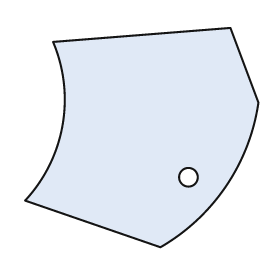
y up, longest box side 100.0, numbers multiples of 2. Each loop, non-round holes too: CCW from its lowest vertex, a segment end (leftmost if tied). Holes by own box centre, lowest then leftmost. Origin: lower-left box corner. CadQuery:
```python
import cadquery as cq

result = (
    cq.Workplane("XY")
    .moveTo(58.0, 0.0)
    .threePointArc((86.0, 26.0), (100.0, 62.0))
    .lineTo(88.0, 94.0)
    .lineTo(12.0, 88.0)
    .threePointArc((16.0, 52.0), (0.0, 20.0))
    .close()
    .moveTo(70.0, 30.0)
    .circle(4.0)
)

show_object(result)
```